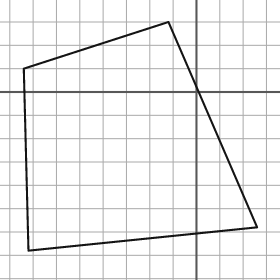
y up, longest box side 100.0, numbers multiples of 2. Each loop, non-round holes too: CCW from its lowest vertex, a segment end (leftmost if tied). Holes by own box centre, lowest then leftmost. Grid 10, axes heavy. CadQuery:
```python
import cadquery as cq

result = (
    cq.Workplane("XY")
    .moveTo(-72.0, -68.0)
    .lineTo(26.0, -58.0)
    .lineTo(-12.0, 30.0)
    .lineTo(-74.0, 10.0)
    .close()
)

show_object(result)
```